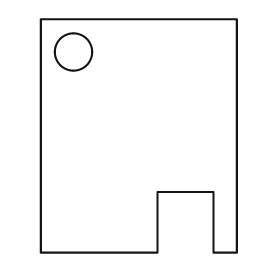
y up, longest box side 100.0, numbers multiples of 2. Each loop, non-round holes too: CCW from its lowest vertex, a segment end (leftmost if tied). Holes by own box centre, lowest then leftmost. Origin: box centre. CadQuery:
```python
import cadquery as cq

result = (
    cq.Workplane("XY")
    .moveTo(-42.0, -50.0)
    .lineTo(8.0, -50.0)
    .lineTo(8.0, -24.0)
    .lineTo(32.0, -24.0)
    .lineTo(32.0, -50.0)
    .lineTo(42.0, -50.0)
    .lineTo(42.0, 50.0)
    .lineTo(-42.0, 50.0)
    .close()
    .moveTo(-28.0, 36.0)
    .circle(8.0)
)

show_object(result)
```